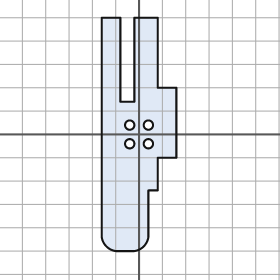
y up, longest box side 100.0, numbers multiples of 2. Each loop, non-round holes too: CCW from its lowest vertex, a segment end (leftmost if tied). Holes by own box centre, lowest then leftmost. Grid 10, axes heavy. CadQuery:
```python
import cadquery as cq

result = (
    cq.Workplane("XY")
    .moveTo(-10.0, -50.0)
    .lineTo(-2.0, -50.0)
    .threePointArc((2.0, -48.0), (4.0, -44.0))
    .lineTo(4.0, -24.0)
    .lineTo(8.0, -24.0)
    .lineTo(8.0, -10.0)
    .lineTo(16.0, -10.0)
    .lineTo(16.0, 20.0)
    .lineTo(8.0, 20.0)
    .lineTo(8.0, 50.0)
    .lineTo(-2.0, 50.0)
    .lineTo(-2.0, 14.0)
    .lineTo(-8.0, 14.0)
    .lineTo(-8.0, 50.0)
    .lineTo(-16.0, 50.0)
    .lineTo(-16.0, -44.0)
    .threePointArc((-14.0, -48.0), (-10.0, -50.0))
    .close()
    .moveTo(-4.0, -4.0)
    .circle(2.0)
    .moveTo(4.0, -4.0)
    .circle(2.0)
    .moveTo(-4.0, 4.0)
    .circle(2.0)
    .moveTo(4.0, 4.0)
    .circle(2.0)
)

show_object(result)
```